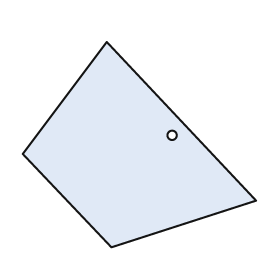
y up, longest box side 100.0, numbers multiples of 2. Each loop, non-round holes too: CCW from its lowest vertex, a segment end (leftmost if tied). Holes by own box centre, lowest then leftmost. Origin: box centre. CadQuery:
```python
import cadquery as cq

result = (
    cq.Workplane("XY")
    .moveTo(-12.0, -44.0)
    .lineTo(50.0, -24.0)
    .lineTo(-14.0, 44.0)
    .lineTo(-50.0, -4.0)
    .close()
    .moveTo(14.0, 4.0)
    .circle(2.0)
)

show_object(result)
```